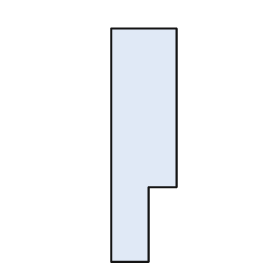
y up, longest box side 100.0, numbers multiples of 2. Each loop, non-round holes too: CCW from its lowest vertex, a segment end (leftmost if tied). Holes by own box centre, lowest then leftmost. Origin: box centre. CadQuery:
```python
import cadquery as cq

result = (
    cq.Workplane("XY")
    .moveTo(-14.0, -50.0)
    .lineTo(2.0, -50.0)
    .lineTo(2.0, -18.0)
    .lineTo(14.0, -18.0)
    .lineTo(14.0, 50.0)
    .lineTo(-14.0, 50.0)
    .close()
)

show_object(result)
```